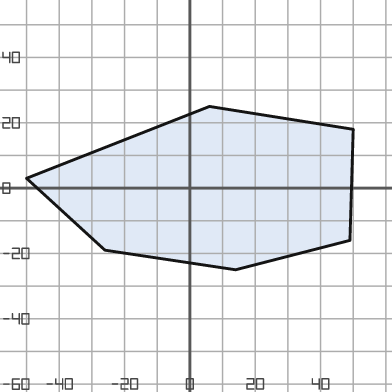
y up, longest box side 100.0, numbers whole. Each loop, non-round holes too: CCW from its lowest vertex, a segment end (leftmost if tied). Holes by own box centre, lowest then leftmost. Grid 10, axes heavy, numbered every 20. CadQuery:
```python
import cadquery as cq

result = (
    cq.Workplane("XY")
    .moveTo(14.0, -25.0)
    .lineTo(49.0, -16.0)
    .lineTo(50.0, 18.0)
    .lineTo(6.0, 25.0)
    .lineTo(-50.0, 3.0)
    .lineTo(-26.0, -19.0)
    .close()
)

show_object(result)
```